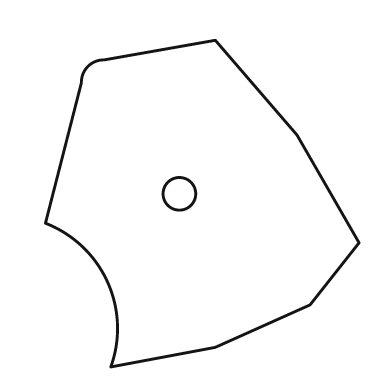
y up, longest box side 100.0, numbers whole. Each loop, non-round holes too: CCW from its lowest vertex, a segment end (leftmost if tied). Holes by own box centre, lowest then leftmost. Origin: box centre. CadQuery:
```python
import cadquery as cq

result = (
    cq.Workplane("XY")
    .moveTo(-28.0, -50.0)
    .lineTo(4.0, -44.0)
    .lineTo(33.0, -31.0)
    .lineTo(48.0, -12.0)
    .lineTo(29.0, 21.0)
    .lineTo(4.0, 50.0)
    .lineTo(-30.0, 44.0)
    .threePointArc((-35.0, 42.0), (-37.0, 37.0))
    .lineTo(-48.0, -6.0)
    .threePointArc((-29.0, -24.0), (-28.0, -50.0))
    .close()
    .moveTo(-7.0, 3.0)
    .circle(5.0)
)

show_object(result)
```